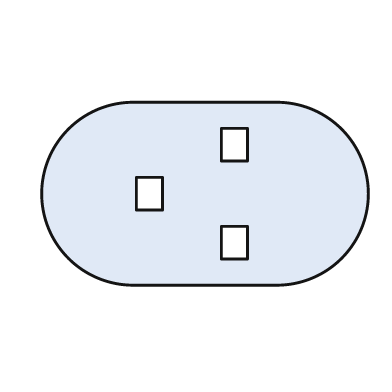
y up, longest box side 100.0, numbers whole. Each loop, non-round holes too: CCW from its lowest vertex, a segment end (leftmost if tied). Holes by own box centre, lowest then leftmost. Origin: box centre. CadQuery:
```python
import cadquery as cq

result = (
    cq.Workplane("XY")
    .moveTo(-22.0, -28.0)
    .lineTo(22.0, -28.0)
    .threePointArc((50.0, 0.0), (22.0, 28.0))
    .lineTo(-22.0, 28.0)
    .threePointArc((-50.0, 0.0), (-22.0, -28.0))
    .close()
    .moveTo(5.0, -20.0)
    .lineTo(13.0, -20.0)
    .lineTo(13.0, -10.0)
    .lineTo(5.0, -10.0)
    .close()
    .moveTo(-21.0, -5.0)
    .lineTo(-13.0, -5.0)
    .lineTo(-13.0, 5.0)
    .lineTo(-21.0, 5.0)
    .close()
    .moveTo(5.0, 10.0)
    .lineTo(13.0, 10.0)
    .lineTo(13.0, 20.0)
    .lineTo(5.0, 20.0)
    .close()
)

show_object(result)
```